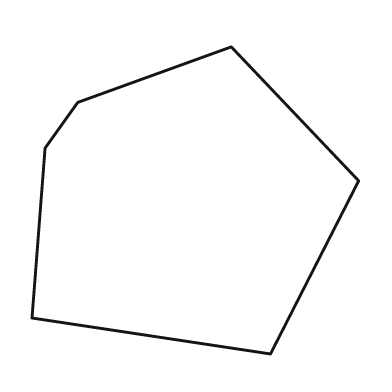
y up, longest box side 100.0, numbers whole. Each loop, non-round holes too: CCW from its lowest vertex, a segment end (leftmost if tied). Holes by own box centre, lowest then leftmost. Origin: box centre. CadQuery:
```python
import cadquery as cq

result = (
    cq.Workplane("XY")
    .moveTo(23.0, -47.0)
    .lineTo(50.0, 6.0)
    .lineTo(11.0, 47.0)
    .lineTo(-36.0, 30.0)
    .lineTo(-46.0, 16.0)
    .lineTo(-50.0, -36.0)
    .close()
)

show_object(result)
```